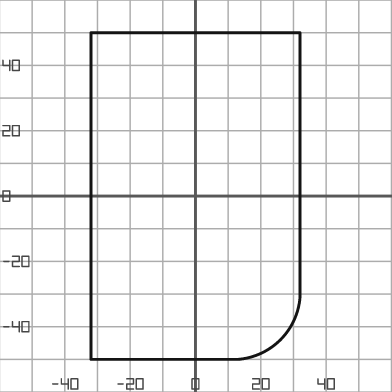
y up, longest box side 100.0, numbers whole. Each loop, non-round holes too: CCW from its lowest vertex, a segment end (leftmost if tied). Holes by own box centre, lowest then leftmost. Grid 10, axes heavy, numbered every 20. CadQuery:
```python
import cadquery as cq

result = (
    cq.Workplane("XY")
    .moveTo(-32.0, -50.0)
    .lineTo(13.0, -50.0)
    .threePointArc((26.0, -44.0), (32.0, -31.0))
    .lineTo(32.0, 50.0)
    .lineTo(-32.0, 50.0)
    .close()
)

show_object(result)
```